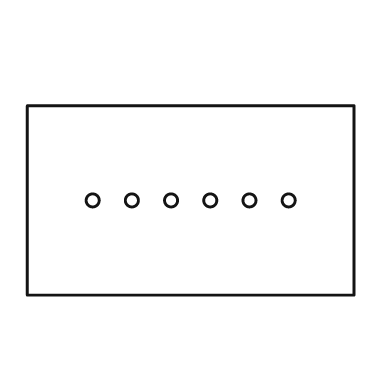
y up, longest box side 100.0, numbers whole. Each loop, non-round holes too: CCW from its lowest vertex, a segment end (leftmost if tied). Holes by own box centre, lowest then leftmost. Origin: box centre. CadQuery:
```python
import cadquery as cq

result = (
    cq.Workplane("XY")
    .moveTo(-50.0, -29.0)
    .lineTo(50.0, -29.0)
    .lineTo(50.0, 29.0)
    .lineTo(-50.0, 29.0)
    .close()
    .moveTo(-30.0, 0.0)
    .circle(2.0)
    .moveTo(-18.0, 0.0)
    .circle(2.0)
    .moveTo(-6.0, 0.0)
    .circle(2.0)
    .moveTo(6.0, 0.0)
    .circle(2.0)
    .moveTo(18.0, 0.0)
    .circle(2.0)
    .moveTo(30.0, 0.0)
    .circle(2.0)
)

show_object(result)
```